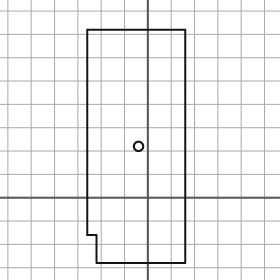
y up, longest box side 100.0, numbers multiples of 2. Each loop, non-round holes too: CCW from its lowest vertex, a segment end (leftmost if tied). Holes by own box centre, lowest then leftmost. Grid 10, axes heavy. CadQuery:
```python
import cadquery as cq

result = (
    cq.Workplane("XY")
    .moveTo(-22.0, -28.0)
    .lineTo(16.0, -28.0)
    .lineTo(16.0, 72.0)
    .lineTo(-26.0, 72.0)
    .lineTo(-26.0, -16.0)
    .lineTo(-22.0, -16.0)
    .close()
    .moveTo(-4.0, 22.0)
    .circle(2.0)
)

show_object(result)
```